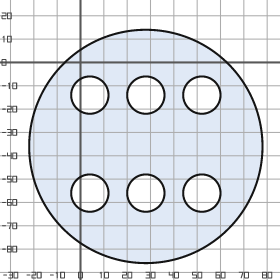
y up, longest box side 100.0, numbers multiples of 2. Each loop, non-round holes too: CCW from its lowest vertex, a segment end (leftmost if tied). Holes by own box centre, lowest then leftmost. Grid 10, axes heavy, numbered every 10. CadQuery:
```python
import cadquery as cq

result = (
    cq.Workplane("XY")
    .moveTo(28.0, -36.0)
    .circle(50.0)
    .moveTo(4.0, -56.0)
    .circle(8.0)
    .moveTo(28.0, -56.0)
    .circle(8.0)
    .moveTo(52.0, -56.0)
    .circle(8.0)
    .moveTo(4.0, -14.0)
    .circle(8.0)
    .moveTo(28.0, -14.0)
    .circle(8.0)
    .moveTo(52.0, -14.0)
    .circle(8.0)
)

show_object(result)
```